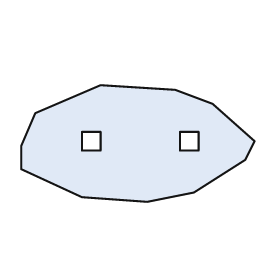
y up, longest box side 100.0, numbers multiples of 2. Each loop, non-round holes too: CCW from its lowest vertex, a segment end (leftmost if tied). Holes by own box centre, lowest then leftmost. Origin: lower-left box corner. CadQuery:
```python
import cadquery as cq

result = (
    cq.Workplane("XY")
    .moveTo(54.0, 0.0)
    .lineTo(74.0, 4.0)
    .lineTo(96.0, 18.0)
    .lineTo(100.0, 26.0)
    .lineTo(82.0, 42.0)
    .lineTo(66.0, 48.0)
    .lineTo(34.0, 50.0)
    .lineTo(6.0, 38.0)
    .lineTo(0.0, 24.0)
    .lineTo(0.0, 14.0)
    .lineTo(26.0, 2.0)
    .close()
    .moveTo(26.0, 22.0)
    .lineTo(34.0, 22.0)
    .lineTo(34.0, 30.0)
    .lineTo(26.0, 30.0)
    .close()
    .moveTo(68.0, 22.0)
    .lineTo(76.0, 22.0)
    .lineTo(76.0, 30.0)
    .lineTo(68.0, 30.0)
    .close()
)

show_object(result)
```